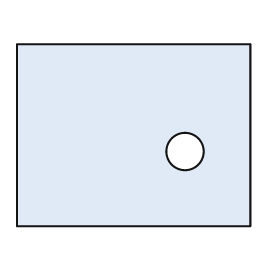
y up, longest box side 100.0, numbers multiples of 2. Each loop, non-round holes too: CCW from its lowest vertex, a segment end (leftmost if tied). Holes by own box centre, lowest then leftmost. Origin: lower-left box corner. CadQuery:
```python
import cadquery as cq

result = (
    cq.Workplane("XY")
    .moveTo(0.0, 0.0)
    .lineTo(100.0, 0.0)
    .lineTo(100.0, 78.0)
    .lineTo(0.0, 78.0)
    .close()
    .moveTo(72.0, 32.0)
    .circle(8.0)
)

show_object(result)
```